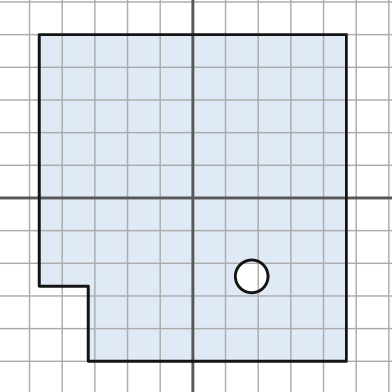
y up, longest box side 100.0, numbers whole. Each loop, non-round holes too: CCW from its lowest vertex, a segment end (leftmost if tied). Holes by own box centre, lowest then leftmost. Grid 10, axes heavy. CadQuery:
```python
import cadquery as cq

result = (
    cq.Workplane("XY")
    .moveTo(-32.0, -50.0)
    .lineTo(47.0, -50.0)
    .lineTo(47.0, 50.0)
    .lineTo(-47.0, 50.0)
    .lineTo(-47.0, -27.0)
    .lineTo(-32.0, -27.0)
    .close()
    .moveTo(18.0, -24.0)
    .circle(5.0)
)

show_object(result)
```